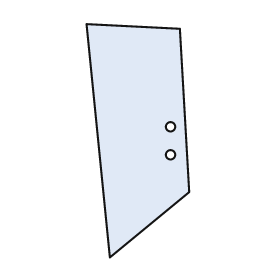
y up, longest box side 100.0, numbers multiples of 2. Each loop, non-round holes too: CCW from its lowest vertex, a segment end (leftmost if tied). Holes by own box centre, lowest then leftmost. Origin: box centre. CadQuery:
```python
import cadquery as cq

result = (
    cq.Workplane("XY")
    .moveTo(-12.0, -50.0)
    .lineTo(22.0, -22.0)
    .lineTo(18.0, 48.0)
    .lineTo(-22.0, 50.0)
    .close()
    .moveTo(14.0, -6.0)
    .circle(2.0)
    .moveTo(14.0, 6.0)
    .circle(2.0)
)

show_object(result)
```